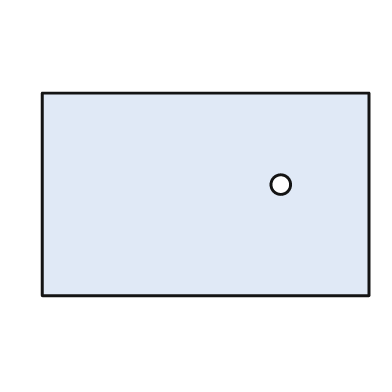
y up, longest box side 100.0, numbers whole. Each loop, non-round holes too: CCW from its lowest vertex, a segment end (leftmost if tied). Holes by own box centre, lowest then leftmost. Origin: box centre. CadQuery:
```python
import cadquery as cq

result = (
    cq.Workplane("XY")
    .moveTo(-50.0, -31.0)
    .lineTo(50.0, -31.0)
    .lineTo(50.0, 31.0)
    .lineTo(-50.0, 31.0)
    .close()
    .moveTo(23.0, 3.0)
    .circle(3.0)
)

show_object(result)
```